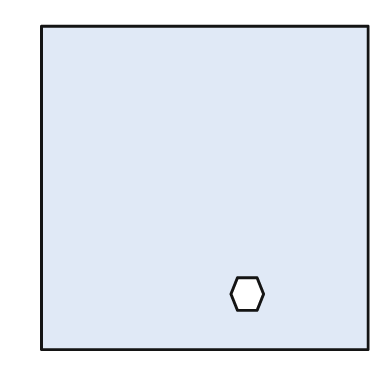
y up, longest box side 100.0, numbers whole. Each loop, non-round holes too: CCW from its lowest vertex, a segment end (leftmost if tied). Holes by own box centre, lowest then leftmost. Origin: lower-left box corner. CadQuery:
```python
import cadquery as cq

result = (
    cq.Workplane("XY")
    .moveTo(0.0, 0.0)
    .lineTo(100.0, 0.0)
    .lineTo(100.0, 99.0)
    .lineTo(0.0, 99.0)
    .close()
    .moveTo(60.0, 12.0)
    .lineTo(66.0, 12.0)
    .lineTo(68.0, 17.0)
    .lineTo(66.0, 22.0)
    .lineTo(60.0, 22.0)
    .lineTo(58.0, 17.0)
    .close()
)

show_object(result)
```